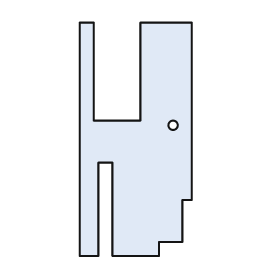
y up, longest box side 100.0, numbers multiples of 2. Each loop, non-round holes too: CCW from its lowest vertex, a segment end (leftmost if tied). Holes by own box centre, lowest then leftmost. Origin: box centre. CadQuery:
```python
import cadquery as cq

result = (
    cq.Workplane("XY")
    .moveTo(-24.0, -50.0)
    .lineTo(-16.0, -50.0)
    .lineTo(-16.0, -10.0)
    .lineTo(-10.0, -10.0)
    .lineTo(-10.0, -50.0)
    .lineTo(10.0, -50.0)
    .lineTo(10.0, -44.0)
    .lineTo(20.0, -44.0)
    .lineTo(20.0, -26.0)
    .lineTo(24.0, -26.0)
    .lineTo(24.0, 50.0)
    .lineTo(2.0, 50.0)
    .lineTo(2.0, 8.0)
    .lineTo(-18.0, 8.0)
    .lineTo(-18.0, 50.0)
    .lineTo(-24.0, 50.0)
    .close()
    .moveTo(16.0, 6.0)
    .circle(2.0)
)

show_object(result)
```